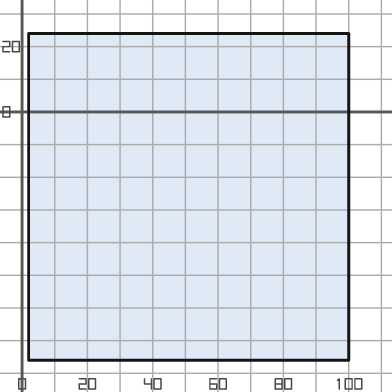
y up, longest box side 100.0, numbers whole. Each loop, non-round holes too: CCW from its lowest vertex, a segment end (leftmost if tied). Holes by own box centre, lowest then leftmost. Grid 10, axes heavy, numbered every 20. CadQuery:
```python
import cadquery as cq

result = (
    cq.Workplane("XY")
    .moveTo(2.0, -76.0)
    .lineTo(100.0, -76.0)
    .lineTo(100.0, 24.0)
    .lineTo(2.0, 24.0)
    .close()
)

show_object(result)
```